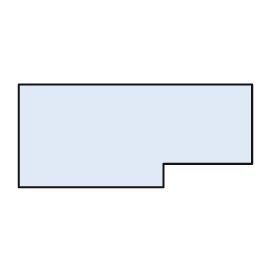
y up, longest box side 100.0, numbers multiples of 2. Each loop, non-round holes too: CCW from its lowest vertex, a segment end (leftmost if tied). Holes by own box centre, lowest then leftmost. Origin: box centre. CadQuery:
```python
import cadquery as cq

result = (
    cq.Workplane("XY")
    .moveTo(-50.0, -22.0)
    .lineTo(12.0, -22.0)
    .lineTo(12.0, -12.0)
    .lineTo(50.0, -12.0)
    .lineTo(50.0, 22.0)
    .lineTo(-50.0, 22.0)
    .close()
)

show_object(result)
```